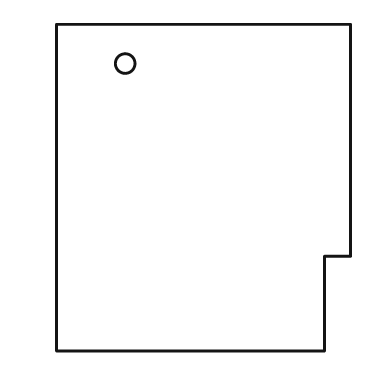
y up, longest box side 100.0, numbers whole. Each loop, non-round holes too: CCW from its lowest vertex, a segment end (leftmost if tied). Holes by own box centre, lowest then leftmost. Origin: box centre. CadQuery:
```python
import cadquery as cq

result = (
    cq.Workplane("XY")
    .moveTo(-45.0, -50.0)
    .lineTo(37.0, -50.0)
    .lineTo(37.0, -21.0)
    .lineTo(45.0, -21.0)
    .lineTo(45.0, 50.0)
    .lineTo(-45.0, 50.0)
    .close()
    .moveTo(-24.0, 38.0)
    .circle(3.0)
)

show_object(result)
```